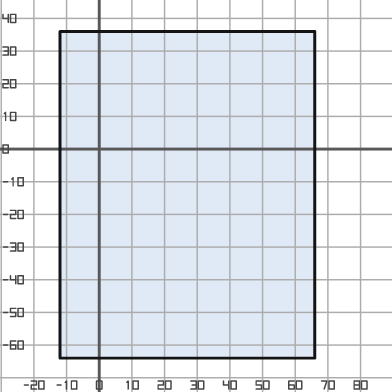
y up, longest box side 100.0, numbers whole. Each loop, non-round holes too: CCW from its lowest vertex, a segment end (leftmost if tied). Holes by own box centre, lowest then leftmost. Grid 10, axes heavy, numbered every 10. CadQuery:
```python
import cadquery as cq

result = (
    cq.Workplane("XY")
    .moveTo(-12.0, -64.0)
    .lineTo(66.0, -64.0)
    .lineTo(66.0, 36.0)
    .lineTo(-12.0, 36.0)
    .close()
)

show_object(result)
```